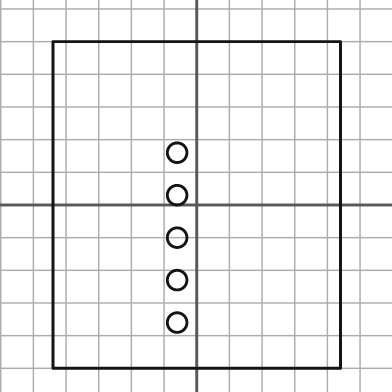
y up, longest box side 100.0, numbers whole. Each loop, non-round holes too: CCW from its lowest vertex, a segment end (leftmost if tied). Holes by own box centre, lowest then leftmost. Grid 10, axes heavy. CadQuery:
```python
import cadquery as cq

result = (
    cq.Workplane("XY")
    .moveTo(-44.0, -50.0)
    .lineTo(44.0, -50.0)
    .lineTo(44.0, 50.0)
    .lineTo(-44.0, 50.0)
    .close()
    .moveTo(-6.0, -36.0)
    .circle(3.0)
    .moveTo(-6.0, -23.0)
    .circle(3.0)
    .moveTo(-6.0, -10.0)
    .circle(3.0)
    .moveTo(-6.0, 3.0)
    .circle(3.0)
    .moveTo(-6.0, 16.0)
    .circle(3.0)
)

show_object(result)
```